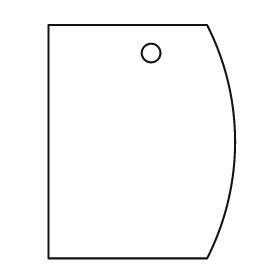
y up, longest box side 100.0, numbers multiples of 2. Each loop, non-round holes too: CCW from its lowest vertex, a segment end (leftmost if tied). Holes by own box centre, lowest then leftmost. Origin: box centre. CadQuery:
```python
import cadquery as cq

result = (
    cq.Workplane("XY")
    .moveTo(-40.0, -50.0)
    .lineTo(28.0, -50.0)
    .threePointArc((40.0, 0.0), (28.0, 50.0))
    .lineTo(-40.0, 50.0)
    .close()
    .moveTo(4.0, 38.0)
    .circle(4.0)
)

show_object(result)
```